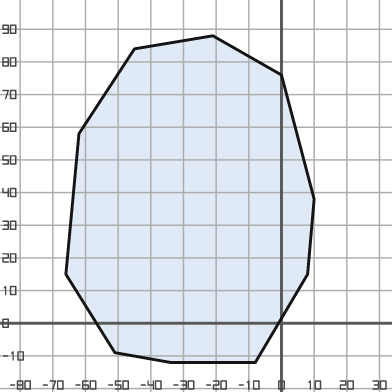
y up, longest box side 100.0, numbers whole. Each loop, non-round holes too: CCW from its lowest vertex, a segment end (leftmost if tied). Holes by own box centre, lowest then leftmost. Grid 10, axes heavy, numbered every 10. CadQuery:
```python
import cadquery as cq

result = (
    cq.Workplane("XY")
    .moveTo(-34.0, -12.0)
    .lineTo(-8.0, -12.0)
    .lineTo(8.0, 15.0)
    .lineTo(10.0, 38.0)
    .lineTo(0.0, 76.0)
    .lineTo(-21.0, 88.0)
    .lineTo(-45.0, 84.0)
    .lineTo(-62.0, 58.0)
    .lineTo(-66.0, 15.0)
    .lineTo(-51.0, -9.0)
    .close()
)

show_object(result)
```